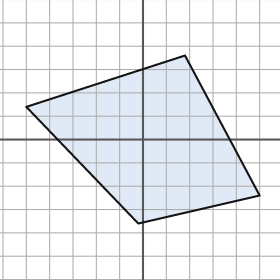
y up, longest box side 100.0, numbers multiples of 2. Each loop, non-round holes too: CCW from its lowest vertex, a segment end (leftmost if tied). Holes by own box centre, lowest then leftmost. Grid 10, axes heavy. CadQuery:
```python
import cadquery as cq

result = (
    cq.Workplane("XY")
    .moveTo(-2.0, -36.0)
    .lineTo(50.0, -24.0)
    .lineTo(18.0, 36.0)
    .lineTo(-50.0, 14.0)
    .close()
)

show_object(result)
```